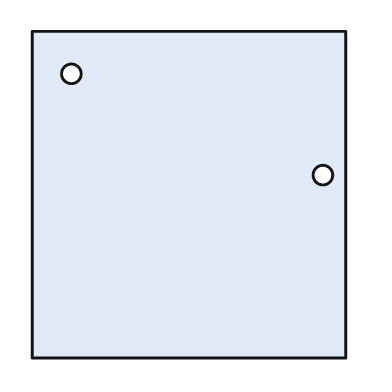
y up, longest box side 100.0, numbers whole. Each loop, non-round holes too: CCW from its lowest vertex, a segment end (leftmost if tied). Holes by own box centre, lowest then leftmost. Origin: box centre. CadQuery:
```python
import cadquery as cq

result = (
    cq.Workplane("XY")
    .moveTo(-48.0, -50.0)
    .lineTo(48.0, -50.0)
    .lineTo(48.0, 50.0)
    .lineTo(-48.0, 50.0)
    .close()
    .moveTo(41.0, 6.0)
    .circle(3.0)
    .moveTo(-36.0, 37.0)
    .circle(3.0)
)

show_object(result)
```